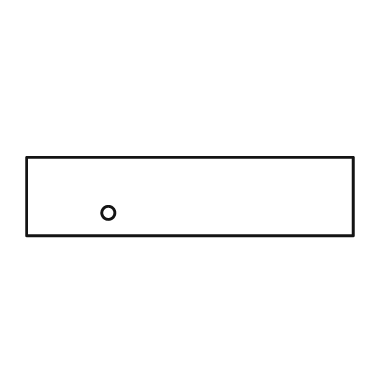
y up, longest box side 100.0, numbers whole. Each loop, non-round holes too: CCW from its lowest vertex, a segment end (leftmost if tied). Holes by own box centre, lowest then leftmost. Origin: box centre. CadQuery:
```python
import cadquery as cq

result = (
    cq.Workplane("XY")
    .moveTo(-50.0, -12.0)
    .lineTo(50.0, -12.0)
    .lineTo(50.0, 12.0)
    .lineTo(-50.0, 12.0)
    .close()
    .moveTo(-25.0, -5.0)
    .circle(2.0)
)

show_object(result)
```